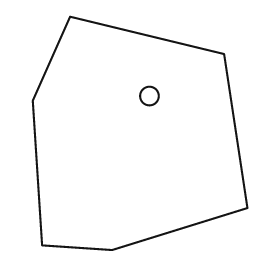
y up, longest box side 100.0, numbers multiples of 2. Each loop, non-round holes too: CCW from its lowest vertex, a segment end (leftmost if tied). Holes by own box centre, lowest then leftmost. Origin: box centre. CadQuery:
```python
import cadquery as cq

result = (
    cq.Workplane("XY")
    .moveTo(-12.0, -50.0)
    .lineTo(46.0, -32.0)
    .lineTo(36.0, 34.0)
    .lineTo(-30.0, 50.0)
    .lineTo(-46.0, 14.0)
    .lineTo(-42.0, -48.0)
    .close()
    .moveTo(4.0, 16.0)
    .circle(4.0)
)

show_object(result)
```